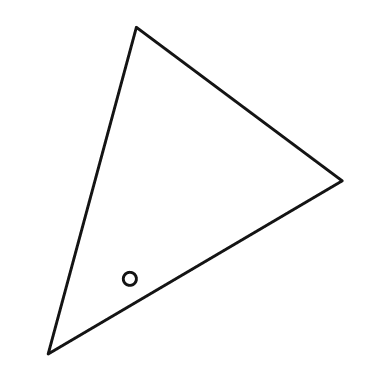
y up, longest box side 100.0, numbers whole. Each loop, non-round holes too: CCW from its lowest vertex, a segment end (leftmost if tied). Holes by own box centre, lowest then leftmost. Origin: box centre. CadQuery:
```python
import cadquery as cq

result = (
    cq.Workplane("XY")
    .moveTo(-45.0, -50.0)
    .lineTo(45.0, 3.0)
    .lineTo(-18.0, 50.0)
    .close()
    .moveTo(-20.0, -27.0)
    .circle(2.0)
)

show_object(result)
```